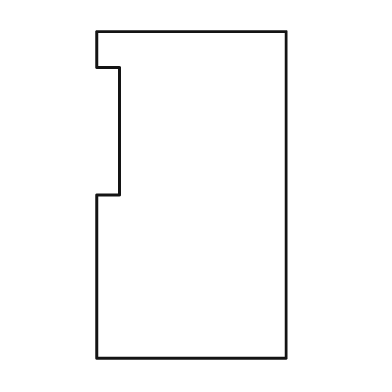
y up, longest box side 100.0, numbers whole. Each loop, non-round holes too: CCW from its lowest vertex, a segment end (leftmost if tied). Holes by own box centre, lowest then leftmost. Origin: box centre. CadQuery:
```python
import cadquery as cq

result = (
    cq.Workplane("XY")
    .moveTo(-29.0, -50.0)
    .lineTo(29.0, -50.0)
    .lineTo(29.0, 50.0)
    .lineTo(-29.0, 50.0)
    .lineTo(-29.0, 39.0)
    .lineTo(-22.0, 39.0)
    .lineTo(-22.0, 0.0)
    .lineTo(-29.0, 0.0)
    .close()
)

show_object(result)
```